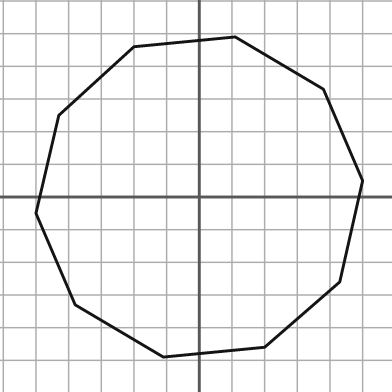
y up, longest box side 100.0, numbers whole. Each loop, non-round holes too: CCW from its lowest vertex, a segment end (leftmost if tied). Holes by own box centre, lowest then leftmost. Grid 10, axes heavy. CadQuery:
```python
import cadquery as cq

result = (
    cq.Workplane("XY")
    .moveTo(-11.0, -49.0)
    .lineTo(20.0, -46.0)
    .lineTo(43.0, -26.0)
    .lineTo(50.0, 5.0)
    .lineTo(38.0, 33.0)
    .lineTo(11.0, 49.0)
    .lineTo(-20.0, 46.0)
    .lineTo(-43.0, 25.0)
    .lineTo(-50.0, -5.0)
    .lineTo(-38.0, -33.0)
    .close()
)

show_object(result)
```